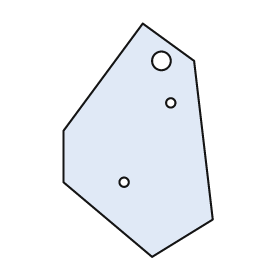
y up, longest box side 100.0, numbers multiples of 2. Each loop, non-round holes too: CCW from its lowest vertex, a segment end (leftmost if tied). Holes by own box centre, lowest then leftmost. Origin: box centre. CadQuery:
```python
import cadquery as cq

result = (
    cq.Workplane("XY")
    .moveTo(6.0, -50.0)
    .lineTo(32.0, -34.0)
    .lineTo(24.0, 34.0)
    .lineTo(2.0, 50.0)
    .lineTo(-32.0, 4.0)
    .lineTo(-32.0, -18.0)
    .close()
    .moveTo(-6.0, -18.0)
    .circle(2.0)
    .moveTo(14.0, 16.0)
    .circle(2.0)
    .moveTo(10.0, 34.0)
    .circle(4.0)
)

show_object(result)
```